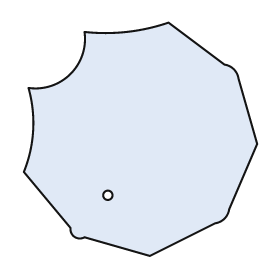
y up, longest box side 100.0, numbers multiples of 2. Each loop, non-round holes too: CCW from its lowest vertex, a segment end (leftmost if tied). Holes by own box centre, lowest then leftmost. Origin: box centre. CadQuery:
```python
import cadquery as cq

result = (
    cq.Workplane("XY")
    .moveTo(4.0, -50.0)
    .lineTo(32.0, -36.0)
    .threePointArc((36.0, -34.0), (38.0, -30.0))
    .lineTo(50.0, -2.0)
    .lineTo(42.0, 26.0)
    .threePointArc((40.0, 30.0), (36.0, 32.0))
    .lineTo(12.0, 50.0)
    .threePointArc((-6.0, 46.0), (-24.0, 46.0))
    .threePointArc((-30.0, 28.0), (-48.0, 22.0))
    .threePointArc((-46.0, 4.0), (-50.0, -14.0))
    .lineTo(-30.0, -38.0)
    .threePointArc((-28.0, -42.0), (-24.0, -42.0))
    .close()
    .moveTo(-14.0, -24.0)
    .circle(2.0)
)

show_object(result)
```